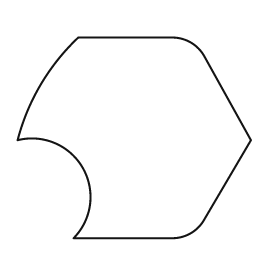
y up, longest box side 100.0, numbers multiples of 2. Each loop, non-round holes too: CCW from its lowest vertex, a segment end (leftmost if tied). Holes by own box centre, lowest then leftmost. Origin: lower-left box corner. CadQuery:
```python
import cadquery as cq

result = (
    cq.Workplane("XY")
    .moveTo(24.0, 0.0)
    .lineTo(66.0, 0.0)
    .threePointArc((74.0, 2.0), (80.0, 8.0))
    .lineTo(100.0, 42.0)
    .lineTo(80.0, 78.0)
    .threePointArc((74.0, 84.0), (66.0, 86.0))
    .lineTo(26.0, 86.0)
    .threePointArc((10.0, 66.0), (0.0, 42.0))
    .threePointArc((28.0, 30.0), (24.0, 0.0))
    .close()
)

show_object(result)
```